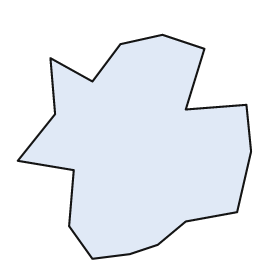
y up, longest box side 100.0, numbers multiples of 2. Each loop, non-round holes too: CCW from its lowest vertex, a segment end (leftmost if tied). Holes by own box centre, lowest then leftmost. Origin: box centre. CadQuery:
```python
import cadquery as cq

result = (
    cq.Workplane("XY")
    .moveTo(-18.0, -48.0)
    .lineTo(-2.0, -46.0)
    .lineTo(10.0, -42.0)
    .lineTo(22.0, -32.0)
    .lineTo(44.0, -28.0)
    .lineTo(50.0, -2.0)
    .lineTo(48.0, 18.0)
    .lineTo(22.0, 16.0)
    .lineTo(30.0, 42.0)
    .lineTo(12.0, 48.0)
    .lineTo(-6.0, 44.0)
    .lineTo(-18.0, 28.0)
    .lineTo(-36.0, 38.0)
    .lineTo(-34.0, 14.0)
    .lineTo(-50.0, -6.0)
    .lineTo(-26.0, -10.0)
    .lineTo(-28.0, -34.0)
    .close()
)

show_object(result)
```